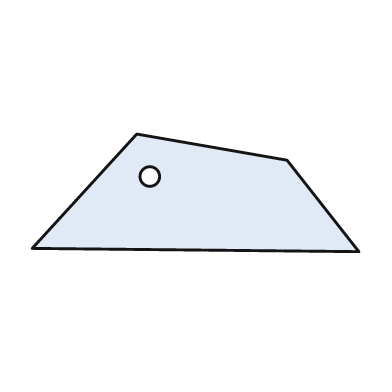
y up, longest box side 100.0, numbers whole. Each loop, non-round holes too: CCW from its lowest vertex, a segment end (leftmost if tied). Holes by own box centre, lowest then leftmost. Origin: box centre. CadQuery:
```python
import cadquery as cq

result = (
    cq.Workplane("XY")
    .moveTo(50.0, -18.0)
    .lineTo(28.0, 10.0)
    .lineTo(-18.0, 18.0)
    .lineTo(-50.0, -17.0)
    .close()
    .moveTo(-14.0, 5.0)
    .circle(3.0)
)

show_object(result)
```